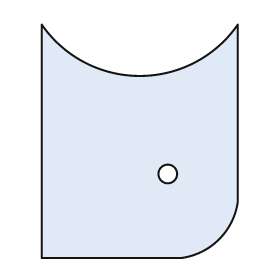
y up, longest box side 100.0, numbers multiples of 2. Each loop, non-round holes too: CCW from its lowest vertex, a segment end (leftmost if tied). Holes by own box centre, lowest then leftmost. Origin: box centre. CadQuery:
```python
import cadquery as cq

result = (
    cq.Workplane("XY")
    .moveTo(-42.0, -50.0)
    .lineTo(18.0, -50.0)
    .threePointArc((34.0, -42.0), (42.0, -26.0))
    .lineTo(42.0, 50.0)
    .threePointArc((0.0, 28.0), (-42.0, 50.0))
    .close()
    .moveTo(12.0, -14.0)
    .circle(4.0)
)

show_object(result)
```